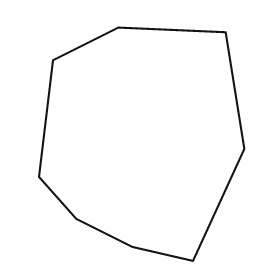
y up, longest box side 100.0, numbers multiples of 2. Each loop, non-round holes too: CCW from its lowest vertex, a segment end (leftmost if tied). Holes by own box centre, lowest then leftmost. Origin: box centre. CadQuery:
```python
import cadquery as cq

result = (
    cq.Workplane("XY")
    .moveTo(22.0, -50.0)
    .lineTo(44.0, -2.0)
    .lineTo(36.0, 48.0)
    .lineTo(-10.0, 50.0)
    .lineTo(-38.0, 36.0)
    .lineTo(-44.0, -14.0)
    .lineTo(-28.0, -32.0)
    .lineTo(-4.0, -44.0)
    .close()
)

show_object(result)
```